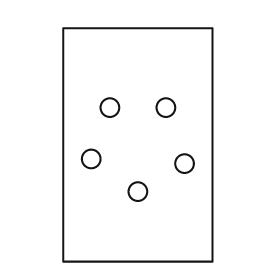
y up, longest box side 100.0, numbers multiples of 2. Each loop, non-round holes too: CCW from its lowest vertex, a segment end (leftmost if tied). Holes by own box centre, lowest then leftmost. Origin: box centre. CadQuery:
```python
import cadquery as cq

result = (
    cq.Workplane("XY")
    .moveTo(-32.0, -50.0)
    .lineTo(32.0, -50.0)
    .lineTo(32.0, 50.0)
    .lineTo(-32.0, 50.0)
    .close()
    .moveTo(0.0, -20.0)
    .circle(4.0)
    .moveTo(20.0, -8.0)
    .circle(4.0)
    .moveTo(-20.0, -6.0)
    .circle(4.0)
    .moveTo(-12.0, 16.0)
    .circle(4.0)
    .moveTo(12.0, 16.0)
    .circle(4.0)
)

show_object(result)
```